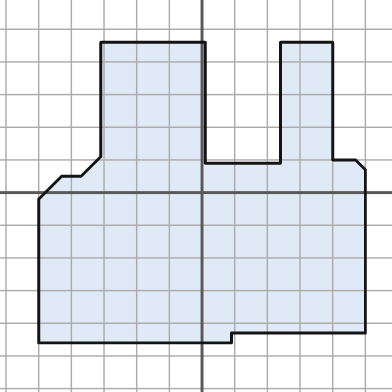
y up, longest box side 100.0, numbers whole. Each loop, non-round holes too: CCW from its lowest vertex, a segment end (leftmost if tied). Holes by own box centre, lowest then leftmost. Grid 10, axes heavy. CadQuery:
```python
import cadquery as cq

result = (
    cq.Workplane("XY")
    .moveTo(-50.0, -46.0)
    .lineTo(9.0, -46.0)
    .lineTo(9.0, -43.0)
    .lineTo(50.0, -43.0)
    .lineTo(50.0, 7.0)
    .lineTo(47.0, 10.0)
    .lineTo(40.0, 10.0)
    .lineTo(40.0, 46.0)
    .lineTo(24.0, 46.0)
    .lineTo(24.0, 9.0)
    .lineTo(1.0, 9.0)
    .lineTo(1.0, 46.0)
    .lineTo(-31.0, 46.0)
    .lineTo(-31.0, 11.0)
    .lineTo(-37.0, 5.0)
    .lineTo(-43.0, 5.0)
    .lineTo(-50.0, -2.0)
    .close()
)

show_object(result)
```